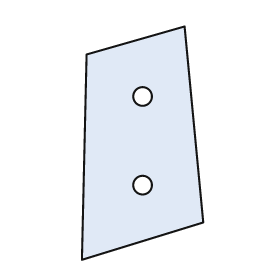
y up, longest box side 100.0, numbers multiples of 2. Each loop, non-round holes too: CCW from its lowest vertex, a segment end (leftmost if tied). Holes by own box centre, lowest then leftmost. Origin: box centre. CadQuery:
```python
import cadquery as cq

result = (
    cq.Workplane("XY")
    .moveTo(-26.0, -50.0)
    .lineTo(26.0, -34.0)
    .lineTo(18.0, 50.0)
    .lineTo(-24.0, 38.0)
    .close()
    .moveTo(0.0, -18.0)
    .circle(4.0)
    .moveTo(0.0, 20.0)
    .circle(4.0)
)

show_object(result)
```